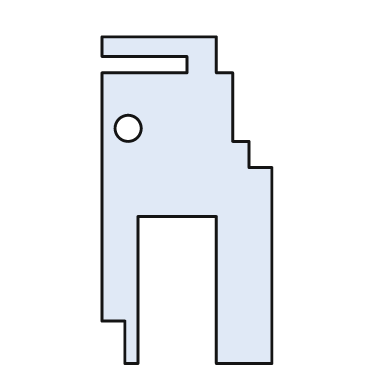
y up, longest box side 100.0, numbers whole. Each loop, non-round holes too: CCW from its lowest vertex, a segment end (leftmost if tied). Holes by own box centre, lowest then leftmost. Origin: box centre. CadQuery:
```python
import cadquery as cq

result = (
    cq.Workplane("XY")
    .moveTo(-19.0, -50.0)
    .lineTo(-15.0, -50.0)
    .lineTo(-15.0, -5.0)
    .lineTo(9.0, -5.0)
    .lineTo(9.0, -50.0)
    .lineTo(26.0, -50.0)
    .lineTo(26.0, 10.0)
    .lineTo(19.0, 10.0)
    .lineTo(19.0, 18.0)
    .lineTo(14.0, 18.0)
    .lineTo(14.0, 39.0)
    .lineTo(9.0, 39.0)
    .lineTo(9.0, 50.0)
    .lineTo(-26.0, 50.0)
    .lineTo(-26.0, 44.0)
    .lineTo(0.0, 44.0)
    .lineTo(0.0, 39.0)
    .lineTo(-26.0, 39.0)
    .lineTo(-26.0, -37.0)
    .lineTo(-19.0, -37.0)
    .close()
    .moveTo(-18.0, 22.0)
    .circle(4.0)
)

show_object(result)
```